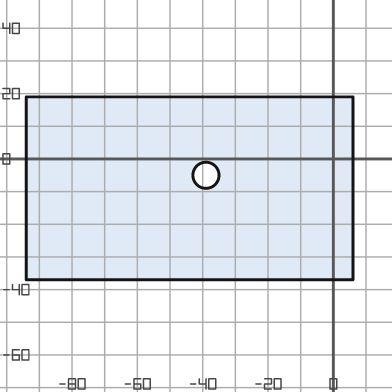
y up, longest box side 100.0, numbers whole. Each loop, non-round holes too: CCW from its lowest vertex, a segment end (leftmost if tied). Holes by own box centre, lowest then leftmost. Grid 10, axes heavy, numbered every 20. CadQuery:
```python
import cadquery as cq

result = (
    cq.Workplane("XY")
    .moveTo(-94.0, -37.0)
    .lineTo(6.0, -37.0)
    .lineTo(6.0, 19.0)
    .lineTo(-94.0, 19.0)
    .close()
    .moveTo(-39.0, -5.0)
    .circle(4.0)
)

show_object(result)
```